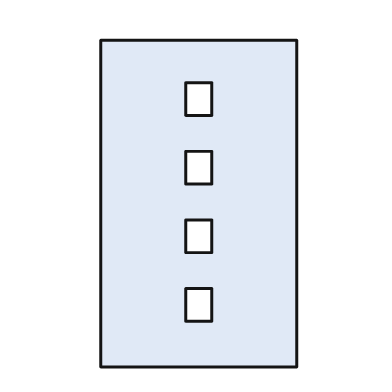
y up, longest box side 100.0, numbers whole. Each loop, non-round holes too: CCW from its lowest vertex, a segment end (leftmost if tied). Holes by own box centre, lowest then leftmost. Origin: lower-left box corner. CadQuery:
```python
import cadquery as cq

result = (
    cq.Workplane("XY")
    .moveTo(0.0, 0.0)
    .lineTo(60.0, 0.0)
    .lineTo(60.0, 100.0)
    .lineTo(0.0, 100.0)
    .close()
    .moveTo(26.0, 14.0)
    .lineTo(34.0, 14.0)
    .lineTo(34.0, 24.0)
    .lineTo(26.0, 24.0)
    .close()
    .moveTo(26.0, 35.0)
    .lineTo(34.0, 35.0)
    .lineTo(34.0, 45.0)
    .lineTo(26.0, 45.0)
    .close()
    .moveTo(26.0, 56.0)
    .lineTo(34.0, 56.0)
    .lineTo(34.0, 66.0)
    .lineTo(26.0, 66.0)
    .close()
    .moveTo(26.0, 77.0)
    .lineTo(34.0, 77.0)
    .lineTo(34.0, 87.0)
    .lineTo(26.0, 87.0)
    .close()
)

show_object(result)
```